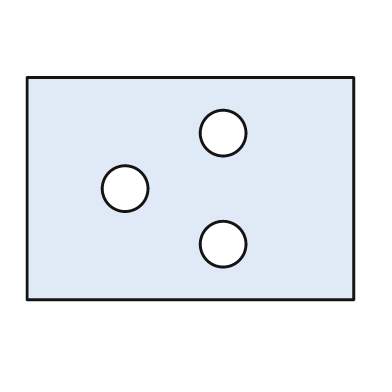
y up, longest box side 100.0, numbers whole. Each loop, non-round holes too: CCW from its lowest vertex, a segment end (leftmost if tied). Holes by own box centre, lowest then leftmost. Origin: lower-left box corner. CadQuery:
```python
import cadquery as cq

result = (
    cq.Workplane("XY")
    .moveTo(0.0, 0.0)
    .lineTo(100.0, 0.0)
    .lineTo(100.0, 68.0)
    .lineTo(0.0, 68.0)
    .close()
    .moveTo(60.0, 17.0)
    .circle(7.0)
    .moveTo(30.0, 34.0)
    .circle(7.0)
    .moveTo(60.0, 51.0)
    .circle(7.0)
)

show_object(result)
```